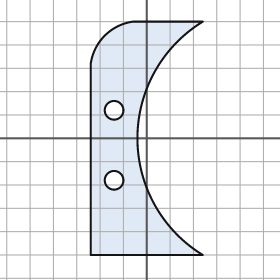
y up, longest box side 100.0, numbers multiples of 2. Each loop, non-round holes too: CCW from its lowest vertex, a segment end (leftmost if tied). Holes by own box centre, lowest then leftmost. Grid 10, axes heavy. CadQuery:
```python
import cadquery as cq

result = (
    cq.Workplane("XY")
    .moveTo(-24.0, -50.0)
    .lineTo(24.0, -50.0)
    .threePointArc((-4.0, 0.0), (24.0, 50.0))
    .lineTo(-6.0, 50.0)
    .threePointArc((-18.0, 44.0), (-24.0, 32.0))
    .close()
    .moveTo(-14.0, -18.0)
    .circle(4.0)
    .moveTo(-14.0, 12.0)
    .circle(4.0)
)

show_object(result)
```